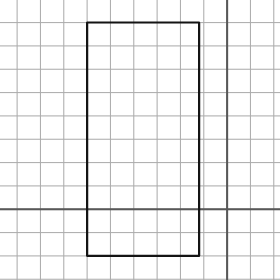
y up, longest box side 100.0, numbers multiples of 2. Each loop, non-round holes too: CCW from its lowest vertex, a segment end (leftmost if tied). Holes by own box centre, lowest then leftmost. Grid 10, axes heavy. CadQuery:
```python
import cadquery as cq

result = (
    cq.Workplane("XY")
    .moveTo(-60.0, -20.0)
    .lineTo(-12.0, -20.0)
    .lineTo(-12.0, 80.0)
    .lineTo(-60.0, 80.0)
    .close()
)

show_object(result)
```